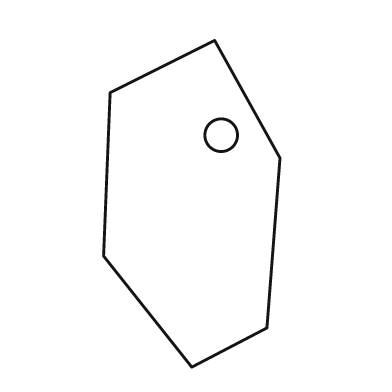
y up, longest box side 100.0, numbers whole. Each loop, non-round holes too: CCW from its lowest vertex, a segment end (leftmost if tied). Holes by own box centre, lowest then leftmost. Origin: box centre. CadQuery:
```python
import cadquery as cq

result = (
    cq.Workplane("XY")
    .moveTo(0.0, -50.0)
    .lineTo(23.0, -38.0)
    .lineTo(27.0, 14.0)
    .lineTo(7.0, 50.0)
    .lineTo(-25.0, 34.0)
    .lineTo(-27.0, -16.0)
    .close()
    .moveTo(9.0, 21.0)
    .circle(5.0)
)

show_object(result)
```